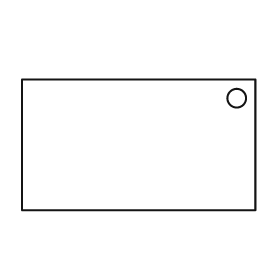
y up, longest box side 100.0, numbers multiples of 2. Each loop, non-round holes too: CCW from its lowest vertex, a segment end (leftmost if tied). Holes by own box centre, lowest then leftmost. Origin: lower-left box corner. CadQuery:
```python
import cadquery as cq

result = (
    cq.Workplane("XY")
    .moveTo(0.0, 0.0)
    .lineTo(100.0, 0.0)
    .lineTo(100.0, 56.0)
    .lineTo(0.0, 56.0)
    .close()
    .moveTo(92.0, 48.0)
    .circle(4.0)
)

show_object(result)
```